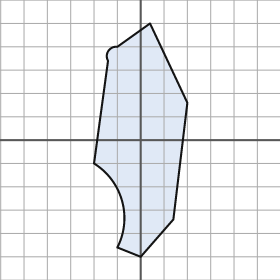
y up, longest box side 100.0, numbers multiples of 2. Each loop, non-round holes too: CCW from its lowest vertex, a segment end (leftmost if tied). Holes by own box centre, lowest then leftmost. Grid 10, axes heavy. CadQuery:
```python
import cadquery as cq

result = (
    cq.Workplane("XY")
    .moveTo(0.0, -50.0)
    .lineTo(14.0, -34.0)
    .lineTo(20.0, 16.0)
    .lineTo(4.0, 50.0)
    .lineTo(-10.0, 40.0)
    .threePointArc((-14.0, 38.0), (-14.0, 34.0))
    .lineTo(-20.0, -10.0)
    .threePointArc((-8.0, -26.0), (-10.0, -46.0))
    .close()
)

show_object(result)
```